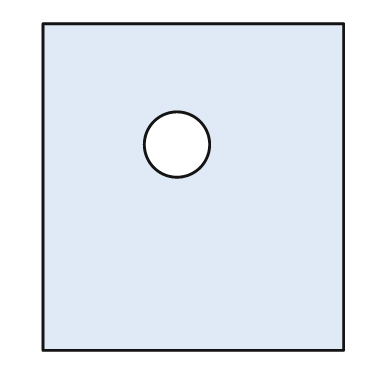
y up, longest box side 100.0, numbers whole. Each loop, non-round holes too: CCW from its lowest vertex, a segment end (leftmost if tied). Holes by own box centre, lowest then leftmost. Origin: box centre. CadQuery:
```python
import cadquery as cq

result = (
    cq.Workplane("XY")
    .moveTo(-46.0, -50.0)
    .lineTo(46.0, -50.0)
    .lineTo(46.0, 50.0)
    .lineTo(-46.0, 50.0)
    .close()
    .moveTo(-5.0, 13.0)
    .circle(10.0)
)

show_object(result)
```